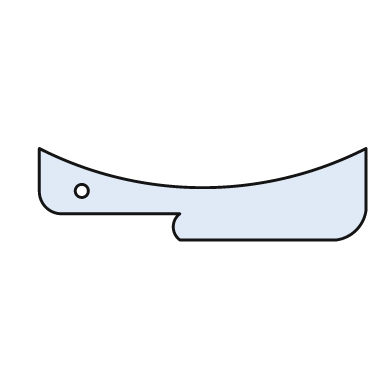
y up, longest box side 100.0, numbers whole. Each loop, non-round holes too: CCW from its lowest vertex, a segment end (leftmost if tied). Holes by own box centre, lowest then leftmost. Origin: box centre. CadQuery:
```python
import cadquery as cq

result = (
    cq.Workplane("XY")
    .moveTo(-7.0, -14.0)
    .lineTo(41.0, -14.0)
    .threePointArc((47.0, -11.0), (50.0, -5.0))
    .lineTo(50.0, 14.0)
    .threePointArc((0.0, 2.0), (-50.0, 14.0))
    .lineTo(-50.0, 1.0)
    .threePointArc((-48.0, -4.0), (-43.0, -6.0))
    .lineTo(-7.0, -6.0)
    .threePointArc((-9.0, -10.0), (-7.0, -14.0))
    .close()
    .moveTo(-37.0, 1.0)
    .circle(2.0)
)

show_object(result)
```